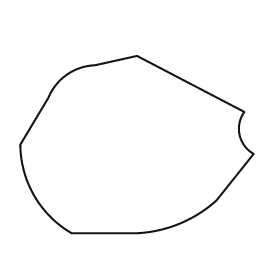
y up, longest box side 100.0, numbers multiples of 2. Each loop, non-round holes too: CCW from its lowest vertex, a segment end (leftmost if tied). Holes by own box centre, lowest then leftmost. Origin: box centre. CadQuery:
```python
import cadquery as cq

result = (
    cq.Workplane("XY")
    .moveTo(-28.0, -38.0)
    .lineTo(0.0, -38.0)
    .threePointArc((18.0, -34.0), (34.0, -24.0))
    .lineTo(50.0, -4.0)
    .threePointArc((44.0, 4.0), (46.0, 14.0))
    .lineTo(0.0, 38.0)
    .lineTo(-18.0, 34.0)
    .threePointArc((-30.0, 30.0), (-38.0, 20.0))
    .lineTo(-50.0, 0.0)
    .threePointArc((-44.0, -22.0), (-28.0, -38.0))
    .close()
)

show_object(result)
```